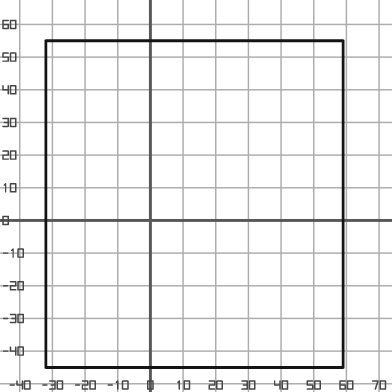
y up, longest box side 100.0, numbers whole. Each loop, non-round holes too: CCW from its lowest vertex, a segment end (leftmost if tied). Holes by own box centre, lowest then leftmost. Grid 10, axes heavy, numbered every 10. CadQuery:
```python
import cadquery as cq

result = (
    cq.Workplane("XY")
    .moveTo(-32.0, -45.0)
    .lineTo(59.0, -45.0)
    .lineTo(59.0, 55.0)
    .lineTo(-32.0, 55.0)
    .close()
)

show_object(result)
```